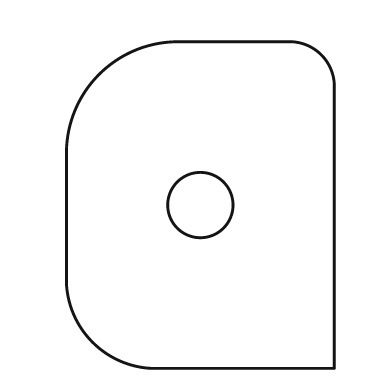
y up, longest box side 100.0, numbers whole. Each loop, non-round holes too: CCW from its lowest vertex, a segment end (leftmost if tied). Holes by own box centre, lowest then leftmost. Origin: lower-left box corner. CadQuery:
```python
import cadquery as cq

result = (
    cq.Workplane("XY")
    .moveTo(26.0, 0.0)
    .lineTo(82.0, 0.0)
    .lineTo(82.0, 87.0)
    .threePointArc((78.0, 96.0), (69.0, 100.0))
    .lineTo(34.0, 100.0)
    .threePointArc((10.0, 90.0), (0.0, 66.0))
    .lineTo(0.0, 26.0)
    .threePointArc((8.0, 8.0), (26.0, 0.0))
    .close()
    .moveTo(41.0, 50.0)
    .circle(10.0)
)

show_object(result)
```